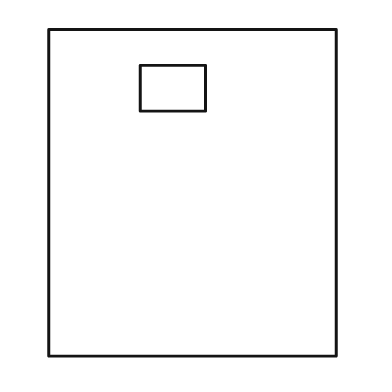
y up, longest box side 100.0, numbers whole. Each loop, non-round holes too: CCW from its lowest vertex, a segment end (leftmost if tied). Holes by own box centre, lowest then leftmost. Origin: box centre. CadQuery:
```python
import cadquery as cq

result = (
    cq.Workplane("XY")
    .moveTo(-44.0, -50.0)
    .lineTo(44.0, -50.0)
    .lineTo(44.0, 50.0)
    .lineTo(-44.0, 50.0)
    .close()
    .moveTo(-16.0, 25.0)
    .lineTo(4.0, 25.0)
    .lineTo(4.0, 39.0)
    .lineTo(-16.0, 39.0)
    .close()
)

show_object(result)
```